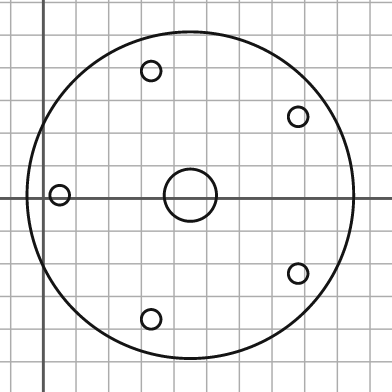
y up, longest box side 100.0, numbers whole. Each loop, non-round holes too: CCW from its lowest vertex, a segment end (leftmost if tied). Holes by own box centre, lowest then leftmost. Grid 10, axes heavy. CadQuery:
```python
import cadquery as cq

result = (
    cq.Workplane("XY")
    .moveTo(45.0, 1.0)
    .circle(50.0)
    .moveTo(33.0, -37.0)
    .circle(3.0)
    .moveTo(78.0, -23.0)
    .circle(3.0)
    .moveTo(5.0, 1.0)
    .circle(3.0)
    .moveTo(45.0, 1.0)
    .circle(8.0)
    .moveTo(78.0, 25.0)
    .circle(3.0)
    .moveTo(33.0, 39.0)
    .circle(3.0)
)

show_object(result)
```